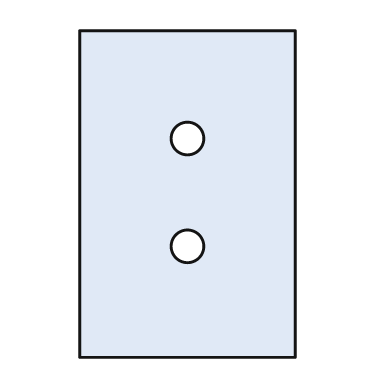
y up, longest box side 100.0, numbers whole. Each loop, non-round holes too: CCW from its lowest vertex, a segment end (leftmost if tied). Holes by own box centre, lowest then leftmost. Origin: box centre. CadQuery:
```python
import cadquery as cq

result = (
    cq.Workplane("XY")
    .moveTo(-33.0, -50.0)
    .lineTo(33.0, -50.0)
    .lineTo(33.0, 50.0)
    .lineTo(-33.0, 50.0)
    .close()
    .moveTo(0.0, -16.0)
    .circle(5.0)
    .moveTo(0.0, 17.0)
    .circle(5.0)
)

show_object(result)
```